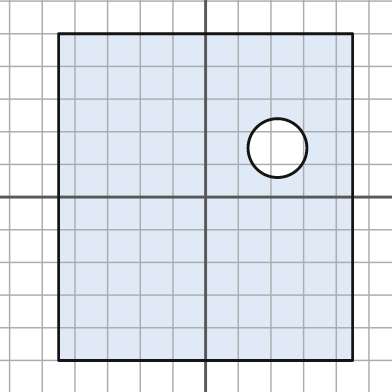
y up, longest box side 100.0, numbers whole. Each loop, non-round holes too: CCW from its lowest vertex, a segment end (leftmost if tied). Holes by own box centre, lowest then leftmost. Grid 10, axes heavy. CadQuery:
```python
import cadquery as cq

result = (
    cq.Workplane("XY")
    .moveTo(-45.0, -50.0)
    .lineTo(45.0, -50.0)
    .lineTo(45.0, 50.0)
    .lineTo(-45.0, 50.0)
    .close()
    .moveTo(22.0, 15.0)
    .circle(9.0)
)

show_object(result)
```